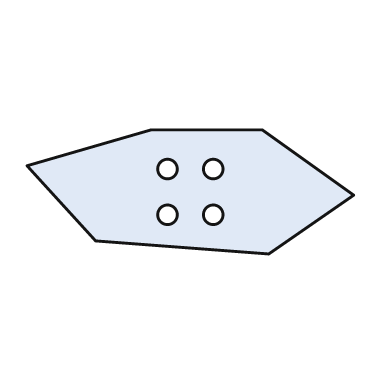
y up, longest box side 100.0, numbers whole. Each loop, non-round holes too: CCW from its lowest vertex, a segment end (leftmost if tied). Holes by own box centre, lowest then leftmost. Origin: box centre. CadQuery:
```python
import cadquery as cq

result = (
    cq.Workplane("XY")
    .moveTo(24.0, -19.0)
    .lineTo(50.0, -1.0)
    .lineTo(22.0, 19.0)
    .lineTo(-12.0, 19.0)
    .lineTo(-50.0, 8.0)
    .lineTo(-29.0, -15.0)
    .close()
    .moveTo(-7.0, -7.0)
    .circle(3.0)
    .moveTo(7.0, -7.0)
    .circle(3.0)
    .moveTo(-7.0, 7.0)
    .circle(3.0)
    .moveTo(7.0, 7.0)
    .circle(3.0)
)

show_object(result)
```